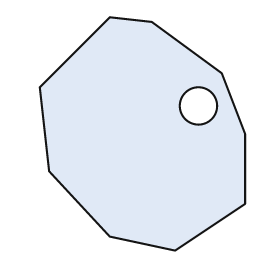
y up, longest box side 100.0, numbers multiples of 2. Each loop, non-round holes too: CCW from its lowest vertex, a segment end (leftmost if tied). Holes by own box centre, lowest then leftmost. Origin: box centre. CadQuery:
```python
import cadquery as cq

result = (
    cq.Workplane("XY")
    .moveTo(14.0, -50.0)
    .lineTo(44.0, -30.0)
    .lineTo(44.0, 0.0)
    .lineTo(34.0, 26.0)
    .lineTo(4.0, 48.0)
    .lineTo(-14.0, 50.0)
    .lineTo(-44.0, 20.0)
    .lineTo(-40.0, -16.0)
    .lineTo(-14.0, -44.0)
    .close()
    .moveTo(24.0, 12.0)
    .circle(8.0)
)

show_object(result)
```